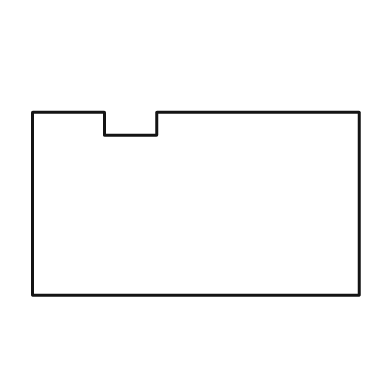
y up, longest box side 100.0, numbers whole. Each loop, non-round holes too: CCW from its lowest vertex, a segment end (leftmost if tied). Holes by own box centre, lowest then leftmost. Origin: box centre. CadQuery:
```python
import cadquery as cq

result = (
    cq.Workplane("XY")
    .moveTo(-50.0, -28.0)
    .lineTo(50.0, -28.0)
    .lineTo(50.0, 28.0)
    .lineTo(-12.0, 28.0)
    .lineTo(-12.0, 21.0)
    .lineTo(-28.0, 21.0)
    .lineTo(-28.0, 28.0)
    .lineTo(-50.0, 28.0)
    .close()
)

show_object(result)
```